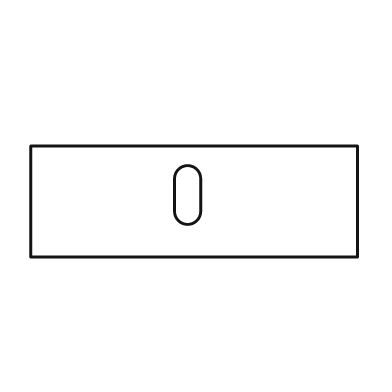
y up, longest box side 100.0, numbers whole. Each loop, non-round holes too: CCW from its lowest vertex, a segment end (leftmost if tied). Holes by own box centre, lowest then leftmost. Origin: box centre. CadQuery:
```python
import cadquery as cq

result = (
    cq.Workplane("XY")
    .moveTo(-50.0, -17.0)
    .lineTo(50.0, -17.0)
    .lineTo(50.0, 17.0)
    .lineTo(-50.0, 17.0)
    .close()
    .moveTo(-6.0, -3.0)
    .threePointArc((-2.0, -7.0), (2.0, -3.0))
    .lineTo(2.0, 7.0)
    .threePointArc((-2.0, 11.0), (-6.0, 7.0))
    .close()
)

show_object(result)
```